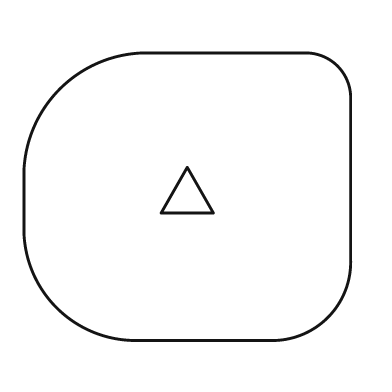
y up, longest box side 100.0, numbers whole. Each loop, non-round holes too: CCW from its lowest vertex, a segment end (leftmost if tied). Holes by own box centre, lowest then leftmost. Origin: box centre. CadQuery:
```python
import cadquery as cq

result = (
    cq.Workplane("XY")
    .moveTo(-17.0, -44.0)
    .lineTo(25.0, -44.0)
    .threePointArc((43.0, -37.0), (50.0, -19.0))
    .lineTo(50.0, 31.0)
    .threePointArc((46.0, 40.0), (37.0, 44.0))
    .lineTo(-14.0, 44.0)
    .threePointArc((-39.0, 33.0), (-50.0, 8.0))
    .lineTo(-50.0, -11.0)
    .threePointArc((-40.0, -34.0), (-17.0, -44.0))
    .close()
    .moveTo(-8.0, -5.0)
    .lineTo(8.0, -5.0)
    .lineTo(0.0, 9.0)
    .close()
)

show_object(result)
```